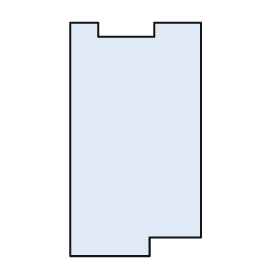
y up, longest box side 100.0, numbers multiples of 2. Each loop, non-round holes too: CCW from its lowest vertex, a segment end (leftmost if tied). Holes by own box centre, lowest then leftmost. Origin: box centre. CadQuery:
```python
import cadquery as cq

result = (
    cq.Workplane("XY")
    .moveTo(-28.0, -50.0)
    .lineTo(6.0, -50.0)
    .lineTo(6.0, -42.0)
    .lineTo(28.0, -42.0)
    .lineTo(28.0, 50.0)
    .lineTo(8.0, 50.0)
    .lineTo(8.0, 44.0)
    .lineTo(-16.0, 44.0)
    .lineTo(-16.0, 50.0)
    .lineTo(-28.0, 50.0)
    .close()
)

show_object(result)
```